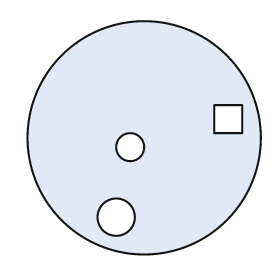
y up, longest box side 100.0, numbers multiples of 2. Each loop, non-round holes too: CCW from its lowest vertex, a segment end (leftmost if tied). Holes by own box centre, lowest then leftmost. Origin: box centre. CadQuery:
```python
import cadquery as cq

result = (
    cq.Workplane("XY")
    .moveTo(0.0, 0.0)
    .circle(50.0)
    .moveTo(-12.0, -34.0)
    .circle(8.0)
    .moveTo(-6.0, -4.0)
    .circle(6.0)
    .moveTo(30.0, 2.0)
    .lineTo(42.0, 2.0)
    .lineTo(42.0, 14.0)
    .lineTo(30.0, 14.0)
    .close()
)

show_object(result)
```